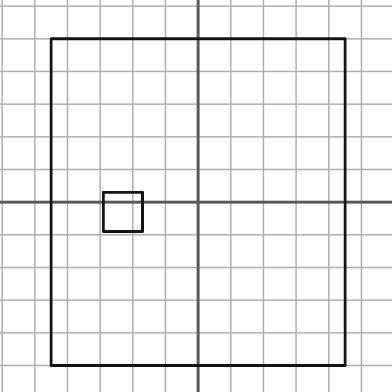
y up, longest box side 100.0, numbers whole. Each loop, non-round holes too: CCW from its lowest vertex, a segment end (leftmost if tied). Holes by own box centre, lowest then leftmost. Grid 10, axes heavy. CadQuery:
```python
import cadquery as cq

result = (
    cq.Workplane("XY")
    .moveTo(-45.0, -50.0)
    .lineTo(45.0, -50.0)
    .lineTo(45.0, 50.0)
    .lineTo(-45.0, 50.0)
    .close()
    .moveTo(-29.0, -9.0)
    .lineTo(-17.0, -9.0)
    .lineTo(-17.0, 3.0)
    .lineTo(-29.0, 3.0)
    .close()
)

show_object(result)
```